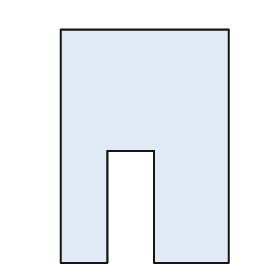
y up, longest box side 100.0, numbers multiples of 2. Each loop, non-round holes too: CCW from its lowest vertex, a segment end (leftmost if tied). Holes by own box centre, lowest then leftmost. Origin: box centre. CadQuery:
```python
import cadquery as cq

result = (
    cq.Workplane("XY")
    .moveTo(-36.0, -50.0)
    .lineTo(-16.0, -50.0)
    .lineTo(-16.0, -2.0)
    .lineTo(4.0, -2.0)
    .lineTo(4.0, -50.0)
    .lineTo(36.0, -50.0)
    .lineTo(36.0, 50.0)
    .lineTo(-36.0, 50.0)
    .close()
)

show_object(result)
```